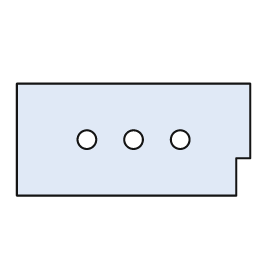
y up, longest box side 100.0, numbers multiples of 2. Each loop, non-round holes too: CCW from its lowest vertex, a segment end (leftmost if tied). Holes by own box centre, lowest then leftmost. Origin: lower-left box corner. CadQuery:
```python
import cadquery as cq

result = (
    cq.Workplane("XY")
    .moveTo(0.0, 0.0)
    .lineTo(94.0, 0.0)
    .lineTo(94.0, 16.0)
    .lineTo(100.0, 16.0)
    .lineTo(100.0, 48.0)
    .lineTo(0.0, 48.0)
    .close()
    .moveTo(30.0, 24.0)
    .circle(4.0)
    .moveTo(50.0, 24.0)
    .circle(4.0)
    .moveTo(70.0, 24.0)
    .circle(4.0)
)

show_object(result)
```